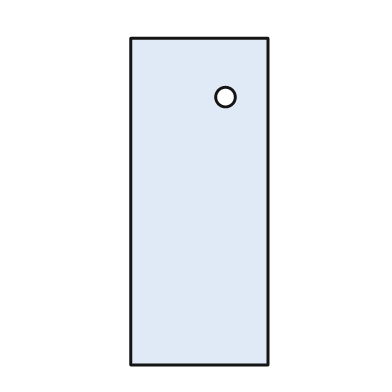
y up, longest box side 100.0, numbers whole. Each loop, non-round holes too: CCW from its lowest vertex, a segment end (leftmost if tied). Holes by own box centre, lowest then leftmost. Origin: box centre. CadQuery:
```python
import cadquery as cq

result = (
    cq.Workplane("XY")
    .moveTo(-21.0, -50.0)
    .lineTo(21.0, -50.0)
    .lineTo(21.0, 50.0)
    .lineTo(-21.0, 50.0)
    .close()
    .moveTo(8.0, 32.0)
    .circle(3.0)
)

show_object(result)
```